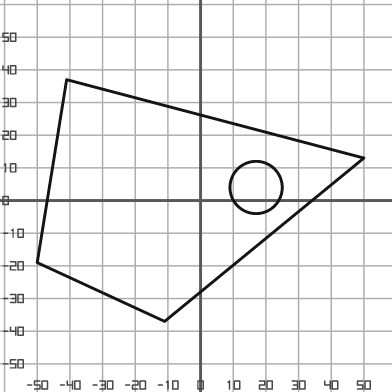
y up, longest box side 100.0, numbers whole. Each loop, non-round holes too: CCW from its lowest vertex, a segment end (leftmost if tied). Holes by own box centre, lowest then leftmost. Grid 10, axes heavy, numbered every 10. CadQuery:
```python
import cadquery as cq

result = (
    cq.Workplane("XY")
    .moveTo(-11.0, -37.0)
    .lineTo(50.0, 13.0)
    .lineTo(-41.0, 37.0)
    .lineTo(-50.0, -19.0)
    .close()
    .moveTo(17.0, 4.0)
    .circle(8.0)
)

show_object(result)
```